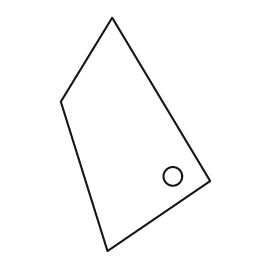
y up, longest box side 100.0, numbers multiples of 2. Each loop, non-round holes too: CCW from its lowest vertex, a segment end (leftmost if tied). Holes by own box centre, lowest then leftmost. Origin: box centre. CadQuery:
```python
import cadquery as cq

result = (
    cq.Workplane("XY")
    .moveTo(-12.0, -50.0)
    .lineTo(32.0, -20.0)
    .lineTo(-10.0, 50.0)
    .lineTo(-32.0, 14.0)
    .close()
    .moveTo(16.0, -18.0)
    .circle(4.0)
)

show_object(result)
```